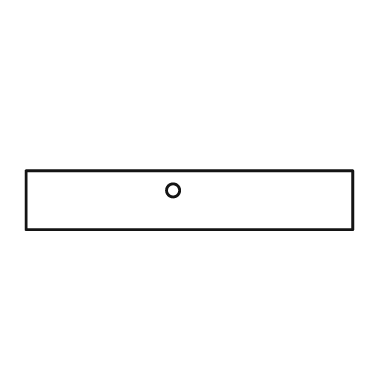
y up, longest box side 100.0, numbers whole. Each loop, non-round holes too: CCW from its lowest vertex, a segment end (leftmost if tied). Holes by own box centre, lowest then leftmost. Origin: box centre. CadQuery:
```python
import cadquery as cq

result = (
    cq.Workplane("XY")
    .moveTo(-50.0, -9.0)
    .lineTo(50.0, -9.0)
    .lineTo(50.0, 9.0)
    .lineTo(-50.0, 9.0)
    .close()
    .moveTo(-5.0, 3.0)
    .circle(2.0)
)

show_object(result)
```